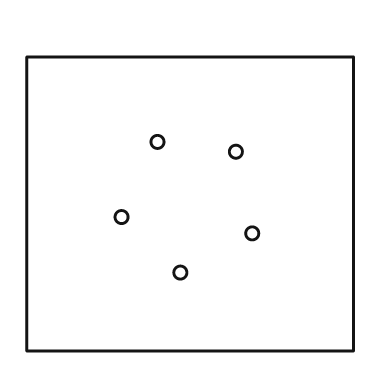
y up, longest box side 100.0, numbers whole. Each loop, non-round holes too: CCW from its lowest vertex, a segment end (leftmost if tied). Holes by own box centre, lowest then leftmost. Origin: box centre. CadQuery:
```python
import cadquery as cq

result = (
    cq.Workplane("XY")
    .moveTo(-50.0, -45.0)
    .lineTo(50.0, -45.0)
    .lineTo(50.0, 45.0)
    .lineTo(-50.0, 45.0)
    .close()
    .moveTo(-3.0, -21.0)
    .circle(2.0)
    .moveTo(19.0, -9.0)
    .circle(2.0)
    .moveTo(-21.0, -4.0)
    .circle(2.0)
    .moveTo(14.0, 16.0)
    .circle(2.0)
    .moveTo(-10.0, 19.0)
    .circle(2.0)
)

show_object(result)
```